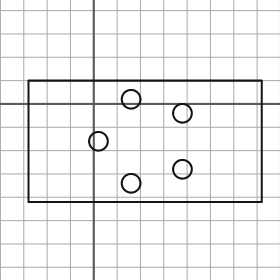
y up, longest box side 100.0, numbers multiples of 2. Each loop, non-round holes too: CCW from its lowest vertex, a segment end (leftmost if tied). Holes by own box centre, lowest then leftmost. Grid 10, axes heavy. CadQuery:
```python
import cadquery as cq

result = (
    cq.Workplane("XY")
    .moveTo(-28.0, -42.0)
    .lineTo(72.0, -42.0)
    .lineTo(72.0, 10.0)
    .lineTo(-28.0, 10.0)
    .close()
    .moveTo(16.0, -34.0)
    .circle(4.0)
    .moveTo(38.0, -28.0)
    .circle(4.0)
    .moveTo(2.0, -16.0)
    .circle(4.0)
    .moveTo(38.0, -4.0)
    .circle(4.0)
    .moveTo(16.0, 2.0)
    .circle(4.0)
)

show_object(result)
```